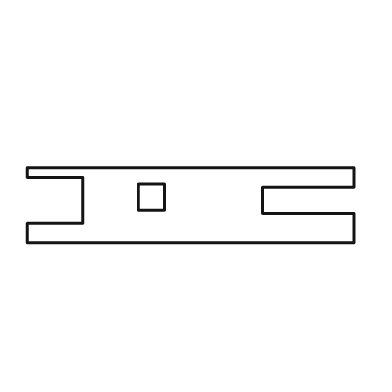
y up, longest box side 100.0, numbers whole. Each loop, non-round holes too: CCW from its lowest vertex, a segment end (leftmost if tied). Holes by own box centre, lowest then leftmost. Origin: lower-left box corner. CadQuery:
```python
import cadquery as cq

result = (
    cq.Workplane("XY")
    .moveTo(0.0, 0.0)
    .lineTo(100.0, 0.0)
    .lineTo(100.0, 9.0)
    .lineTo(72.0, 9.0)
    .lineTo(72.0, 17.0)
    .lineTo(100.0, 17.0)
    .lineTo(100.0, 23.0)
    .lineTo(0.0, 23.0)
    .lineTo(0.0, 20.0)
    .lineTo(17.0, 20.0)
    .lineTo(17.0, 6.0)
    .lineTo(0.0, 6.0)
    .close()
    .moveTo(34.0, 10.0)
    .lineTo(42.0, 10.0)
    .lineTo(42.0, 18.0)
    .lineTo(34.0, 18.0)
    .close()
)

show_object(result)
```